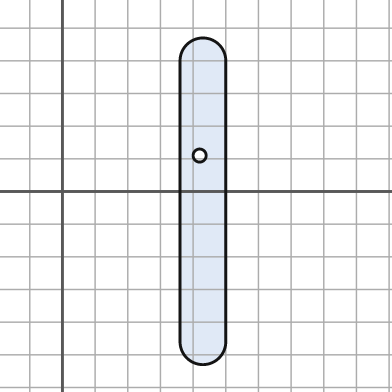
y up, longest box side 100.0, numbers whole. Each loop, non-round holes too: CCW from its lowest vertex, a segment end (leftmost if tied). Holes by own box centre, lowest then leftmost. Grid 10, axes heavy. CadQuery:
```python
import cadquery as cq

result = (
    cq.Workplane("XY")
    .moveTo(36.0, -46.0)
    .threePointArc((43.0, -53.0), (50.0, -46.0))
    .lineTo(50.0, 40.0)
    .threePointArc((43.0, 47.0), (36.0, 40.0))
    .close()
    .moveTo(42.0, 11.0)
    .circle(2.0)
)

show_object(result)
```